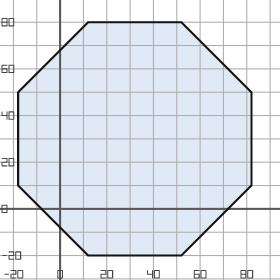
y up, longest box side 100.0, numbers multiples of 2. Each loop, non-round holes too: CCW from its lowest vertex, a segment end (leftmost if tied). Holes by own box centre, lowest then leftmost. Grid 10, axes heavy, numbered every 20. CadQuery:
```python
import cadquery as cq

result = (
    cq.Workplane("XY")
    .moveTo(12.0, -20.0)
    .lineTo(52.0, -20.0)
    .lineTo(82.0, 10.0)
    .lineTo(82.0, 50.0)
    .lineTo(52.0, 80.0)
    .lineTo(12.0, 80.0)
    .lineTo(-18.0, 50.0)
    .lineTo(-18.0, 10.0)
    .close()
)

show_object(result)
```